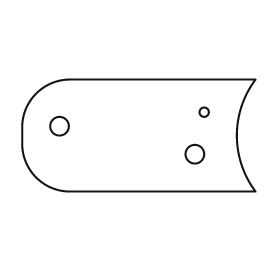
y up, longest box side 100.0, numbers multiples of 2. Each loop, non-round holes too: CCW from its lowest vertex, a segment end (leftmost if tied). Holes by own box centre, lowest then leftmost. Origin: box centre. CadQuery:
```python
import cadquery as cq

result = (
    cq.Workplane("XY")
    .moveTo(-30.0, -24.0)
    .lineTo(50.0, -24.0)
    .threePointArc((42.0, 0.0), (50.0, 24.0))
    .lineTo(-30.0, 24.0)
    .threePointArc((-44.0, 18.0), (-50.0, 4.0))
    .lineTo(-50.0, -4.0)
    .threePointArc((-44.0, -18.0), (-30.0, -24.0))
    .close()
    .moveTo(24.0, -8.0)
    .circle(4.0)
    .moveTo(-34.0, 4.0)
    .circle(4.0)
    .moveTo(28.0, 10.0)
    .circle(2.0)
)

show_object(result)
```